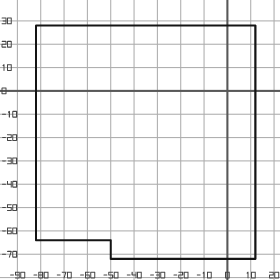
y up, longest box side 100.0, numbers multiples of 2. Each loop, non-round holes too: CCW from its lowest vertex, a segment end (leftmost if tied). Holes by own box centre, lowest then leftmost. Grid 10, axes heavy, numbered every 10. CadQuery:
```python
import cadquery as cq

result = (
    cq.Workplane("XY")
    .moveTo(-50.0, -72.0)
    .lineTo(12.0, -72.0)
    .lineTo(12.0, 28.0)
    .lineTo(-82.0, 28.0)
    .lineTo(-82.0, -64.0)
    .lineTo(-50.0, -64.0)
    .close()
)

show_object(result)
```